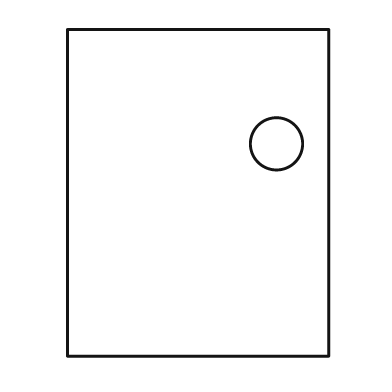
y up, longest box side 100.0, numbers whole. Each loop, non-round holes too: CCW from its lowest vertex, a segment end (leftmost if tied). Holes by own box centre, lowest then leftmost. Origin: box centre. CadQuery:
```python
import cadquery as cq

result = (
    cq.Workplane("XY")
    .moveTo(-40.0, -50.0)
    .lineTo(40.0, -50.0)
    .lineTo(40.0, 50.0)
    .lineTo(-40.0, 50.0)
    .close()
    .moveTo(24.0, 15.0)
    .circle(8.0)
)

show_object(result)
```